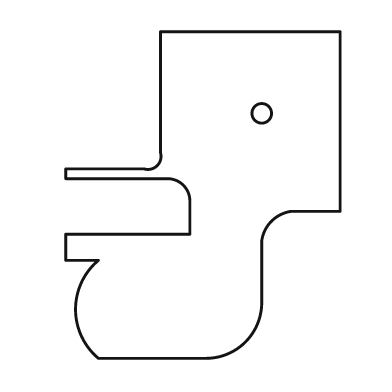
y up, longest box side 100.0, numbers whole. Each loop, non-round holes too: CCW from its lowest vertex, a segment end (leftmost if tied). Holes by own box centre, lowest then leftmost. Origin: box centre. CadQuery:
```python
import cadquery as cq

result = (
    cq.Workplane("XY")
    .moveTo(-32.0, -50.0)
    .lineTo(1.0, -50.0)
    .threePointArc((13.0, -45.0), (18.0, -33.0))
    .lineTo(18.0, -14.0)
    .threePointArc((21.0, -8.0), (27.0, -5.0))
    .lineTo(42.0, -5.0)
    .lineTo(42.0, 50.0)
    .lineTo(-13.0, 50.0)
    .lineTo(-13.0, 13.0)
    .threePointArc((-14.0, 9.0), (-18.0, 8.0))
    .lineTo(-42.0, 8.0)
    .lineTo(-42.0, 5.0)
    .lineTo(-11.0, 5.0)
    .threePointArc((-6.0, 3.0), (-4.0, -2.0))
    .lineTo(-4.0, -12.0)
    .lineTo(-42.0, -12.0)
    .lineTo(-42.0, -20.0)
    .lineTo(-32.0, -20.0)
    .threePointArc((-39.0, -35.0), (-32.0, -50.0))
    .close()
    .moveTo(18.0, 25.0)
    .circle(3.0)
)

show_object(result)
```